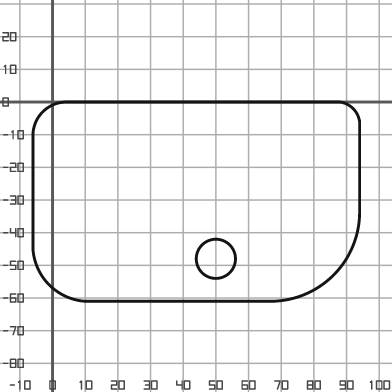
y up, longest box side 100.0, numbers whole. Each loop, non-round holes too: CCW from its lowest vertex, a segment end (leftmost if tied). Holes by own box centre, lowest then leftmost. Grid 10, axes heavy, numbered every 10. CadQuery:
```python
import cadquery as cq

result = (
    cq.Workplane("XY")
    .moveTo(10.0, -61.0)
    .lineTo(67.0, -61.0)
    .threePointArc((86.0, -53.0), (94.0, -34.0))
    .lineTo(94.0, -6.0)
    .threePointArc((92.0, -2.0), (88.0, 0.0))
    .lineTo(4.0, 0.0)
    .threePointArc((-3.0, -3.0), (-6.0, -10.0))
    .lineTo(-6.0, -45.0)
    .threePointArc((-1.0, -56.0), (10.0, -61.0))
    .close()
    .moveTo(50.0, -48.0)
    .circle(6.0)
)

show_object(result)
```